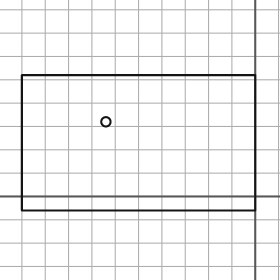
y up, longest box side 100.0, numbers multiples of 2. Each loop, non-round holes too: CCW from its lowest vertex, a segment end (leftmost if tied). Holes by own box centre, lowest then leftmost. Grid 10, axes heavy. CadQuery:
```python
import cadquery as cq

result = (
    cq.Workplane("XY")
    .moveTo(-100.0, -6.0)
    .lineTo(0.0, -6.0)
    .lineTo(0.0, 52.0)
    .lineTo(-100.0, 52.0)
    .close()
    .moveTo(-64.0, 32.0)
    .circle(2.0)
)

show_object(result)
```